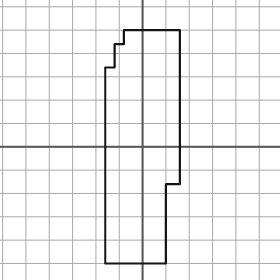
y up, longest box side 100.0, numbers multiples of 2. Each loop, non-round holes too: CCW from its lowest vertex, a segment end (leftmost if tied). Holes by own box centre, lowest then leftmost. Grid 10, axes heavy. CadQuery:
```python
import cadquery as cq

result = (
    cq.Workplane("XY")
    .moveTo(-16.0, -50.0)
    .lineTo(10.0, -50.0)
    .lineTo(10.0, -16.0)
    .lineTo(16.0, -16.0)
    .lineTo(16.0, 50.0)
    .lineTo(-8.0, 50.0)
    .lineTo(-8.0, 44.0)
    .lineTo(-12.0, 44.0)
    .lineTo(-12.0, 34.0)
    .lineTo(-16.0, 34.0)
    .close()
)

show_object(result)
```